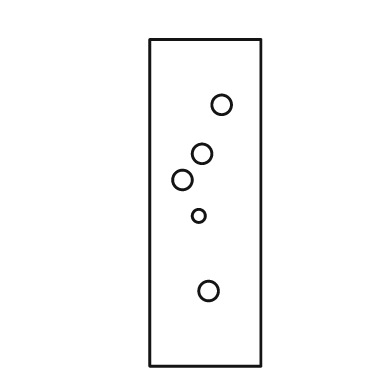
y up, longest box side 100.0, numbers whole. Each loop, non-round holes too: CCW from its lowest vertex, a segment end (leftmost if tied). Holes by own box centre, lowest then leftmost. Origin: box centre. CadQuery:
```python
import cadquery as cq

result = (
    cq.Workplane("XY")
    .moveTo(-17.0, -50.0)
    .lineTo(17.0, -50.0)
    .lineTo(17.0, 50.0)
    .lineTo(-17.0, 50.0)
    .close()
    .moveTo(1.0, -27.0)
    .circle(3.0)
    .moveTo(-2.0, -4.0)
    .circle(2.0)
    .moveTo(-7.0, 7.0)
    .circle(3.0)
    .moveTo(-1.0, 15.0)
    .circle(3.0)
    .moveTo(5.0, 30.0)
    .circle(3.0)
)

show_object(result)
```